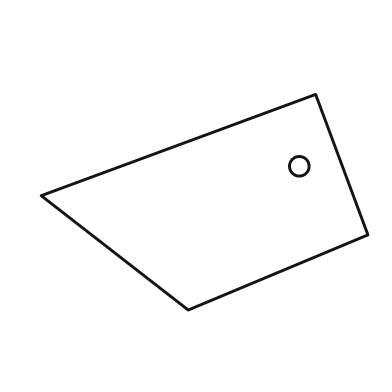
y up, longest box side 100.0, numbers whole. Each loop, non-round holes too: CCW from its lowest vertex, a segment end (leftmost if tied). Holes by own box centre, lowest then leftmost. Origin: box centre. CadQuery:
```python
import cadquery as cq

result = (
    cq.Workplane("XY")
    .moveTo(-5.0, -33.0)
    .lineTo(50.0, -10.0)
    .lineTo(34.0, 33.0)
    .lineTo(-50.0, 2.0)
    .close()
    .moveTo(29.0, 11.0)
    .circle(3.0)
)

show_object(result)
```